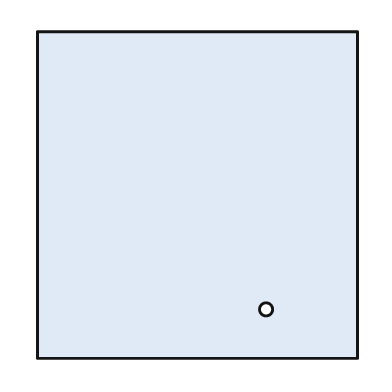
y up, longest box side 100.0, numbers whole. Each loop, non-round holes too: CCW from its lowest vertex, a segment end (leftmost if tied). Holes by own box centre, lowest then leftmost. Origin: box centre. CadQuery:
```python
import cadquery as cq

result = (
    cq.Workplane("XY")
    .moveTo(-49.0, -50.0)
    .lineTo(49.0, -50.0)
    .lineTo(49.0, 50.0)
    .lineTo(-49.0, 50.0)
    .close()
    .moveTo(21.0, -35.0)
    .circle(2.0)
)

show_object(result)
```